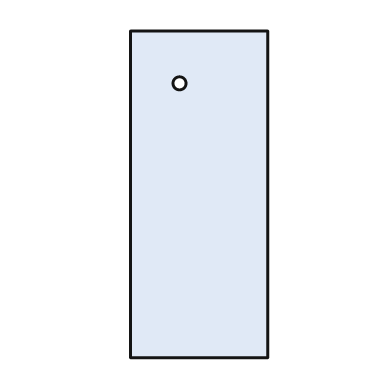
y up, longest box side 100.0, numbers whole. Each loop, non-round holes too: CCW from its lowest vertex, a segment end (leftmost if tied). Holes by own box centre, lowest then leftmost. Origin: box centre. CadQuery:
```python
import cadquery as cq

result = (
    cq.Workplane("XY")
    .moveTo(-21.0, -50.0)
    .lineTo(21.0, -50.0)
    .lineTo(21.0, 50.0)
    .lineTo(-21.0, 50.0)
    .close()
    .moveTo(-6.0, 34.0)
    .circle(2.0)
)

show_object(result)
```